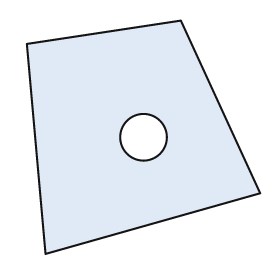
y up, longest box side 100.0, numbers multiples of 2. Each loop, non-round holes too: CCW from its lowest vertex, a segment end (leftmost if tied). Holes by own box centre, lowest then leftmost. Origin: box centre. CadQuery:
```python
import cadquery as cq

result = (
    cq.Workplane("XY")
    .moveTo(-42.0, -50.0)
    .lineTo(50.0, -24.0)
    .lineTo(16.0, 50.0)
    .lineTo(-50.0, 40.0)
    .close()
    .moveTo(0.0, 0.0)
    .circle(10.0)
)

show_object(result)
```